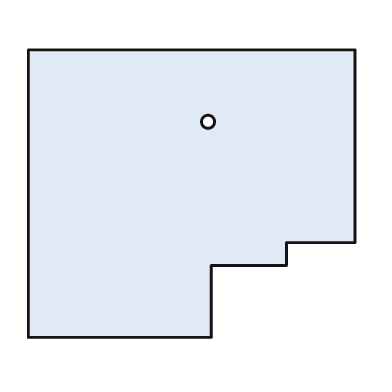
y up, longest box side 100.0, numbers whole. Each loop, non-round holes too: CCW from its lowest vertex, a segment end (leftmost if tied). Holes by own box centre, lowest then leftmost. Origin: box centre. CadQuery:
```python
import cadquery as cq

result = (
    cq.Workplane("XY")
    .moveTo(-50.0, -44.0)
    .lineTo(6.0, -44.0)
    .lineTo(6.0, -22.0)
    .lineTo(29.0, -22.0)
    .lineTo(29.0, -15.0)
    .lineTo(50.0, -15.0)
    .lineTo(50.0, 44.0)
    .lineTo(-50.0, 44.0)
    .close()
    .moveTo(5.0, 22.0)
    .circle(2.0)
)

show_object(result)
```